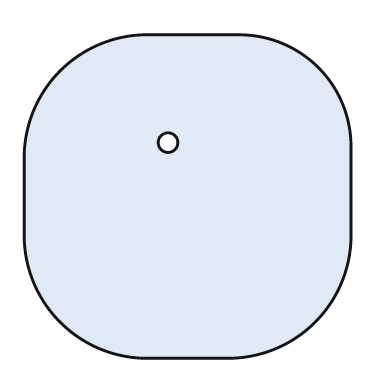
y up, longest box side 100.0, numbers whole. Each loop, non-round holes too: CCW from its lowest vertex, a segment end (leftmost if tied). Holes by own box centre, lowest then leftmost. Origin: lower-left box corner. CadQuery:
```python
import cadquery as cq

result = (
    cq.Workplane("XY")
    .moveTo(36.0, 0.0)
    .lineTo(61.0, 0.0)
    .threePointArc((89.0, 11.0), (100.0, 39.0))
    .lineTo(100.0, 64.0)
    .threePointArc((90.0, 89.0), (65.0, 99.0))
    .lineTo(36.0, 99.0)
    .threePointArc((11.0, 88.0), (0.0, 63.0))
    .lineTo(0.0, 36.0)
    .threePointArc((11.0, 11.0), (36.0, 0.0))
    .close()
    .moveTo(44.0, 66.0)
    .circle(3.0)
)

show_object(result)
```